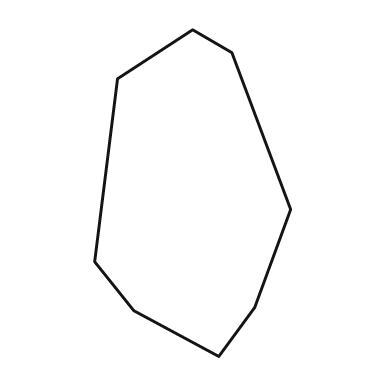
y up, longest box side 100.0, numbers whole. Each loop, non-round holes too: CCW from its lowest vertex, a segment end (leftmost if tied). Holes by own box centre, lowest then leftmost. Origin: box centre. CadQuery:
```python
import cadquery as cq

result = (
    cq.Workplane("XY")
    .moveTo(8.0, -50.0)
    .lineTo(19.0, -35.0)
    .lineTo(30.0, -5.0)
    .lineTo(12.0, 43.0)
    .lineTo(0.0, 50.0)
    .lineTo(-23.0, 35.0)
    .lineTo(-30.0, -21.0)
    .lineTo(-18.0, -36.0)
    .close()
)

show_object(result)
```